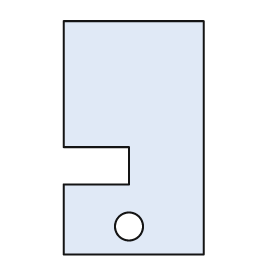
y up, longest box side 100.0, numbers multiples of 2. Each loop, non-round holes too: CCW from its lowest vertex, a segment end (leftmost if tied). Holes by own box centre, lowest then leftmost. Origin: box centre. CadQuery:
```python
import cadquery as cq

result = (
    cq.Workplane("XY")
    .moveTo(-30.0, -50.0)
    .lineTo(30.0, -50.0)
    .lineTo(30.0, 50.0)
    .lineTo(-30.0, 50.0)
    .lineTo(-30.0, -4.0)
    .lineTo(-2.0, -4.0)
    .lineTo(-2.0, -20.0)
    .lineTo(-30.0, -20.0)
    .close()
    .moveTo(-2.0, -38.0)
    .circle(6.0)
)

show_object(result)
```